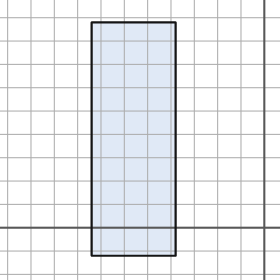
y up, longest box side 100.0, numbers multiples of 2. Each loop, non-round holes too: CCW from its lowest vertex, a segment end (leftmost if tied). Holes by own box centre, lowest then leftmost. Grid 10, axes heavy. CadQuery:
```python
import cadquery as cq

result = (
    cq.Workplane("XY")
    .moveTo(-74.0, -12.0)
    .lineTo(-38.0, -12.0)
    .lineTo(-38.0, 88.0)
    .lineTo(-74.0, 88.0)
    .close()
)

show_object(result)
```